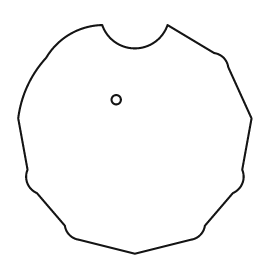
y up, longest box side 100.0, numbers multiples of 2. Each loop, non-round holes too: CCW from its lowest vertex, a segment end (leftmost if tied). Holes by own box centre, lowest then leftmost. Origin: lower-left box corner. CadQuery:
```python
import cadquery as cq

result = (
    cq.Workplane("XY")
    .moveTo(50.0, 0.0)
    .lineTo(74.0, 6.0)
    .threePointArc((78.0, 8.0), (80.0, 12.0))
    .lineTo(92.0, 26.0)
    .threePointArc((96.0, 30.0), (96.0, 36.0))
    .lineTo(100.0, 58.0)
    .lineTo(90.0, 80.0)
    .threePointArc((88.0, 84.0), (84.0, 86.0))
    .lineTo(64.0, 98.0)
    .threePointArc((50.0, 88.0), (36.0, 98.0))
    .threePointArc((22.0, 94.0), (12.0, 84.0))
    .threePointArc((4.0, 72.0), (0.0, 58.0))
    .lineTo(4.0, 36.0)
    .threePointArc((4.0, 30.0), (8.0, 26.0))
    .lineTo(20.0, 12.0)
    .threePointArc((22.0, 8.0), (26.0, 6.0))
    .close()
    .moveTo(42.0, 66.0)
    .circle(2.0)
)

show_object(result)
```